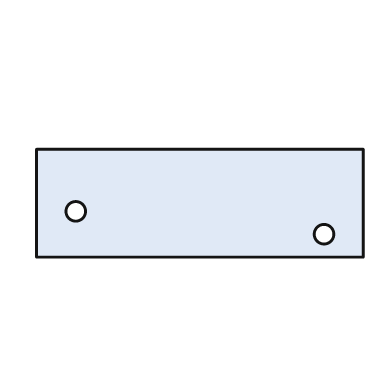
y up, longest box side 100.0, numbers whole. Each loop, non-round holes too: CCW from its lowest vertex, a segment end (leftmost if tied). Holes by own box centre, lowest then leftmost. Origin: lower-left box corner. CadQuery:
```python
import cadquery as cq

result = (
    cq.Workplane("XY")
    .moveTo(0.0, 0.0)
    .lineTo(100.0, 0.0)
    .lineTo(100.0, 33.0)
    .lineTo(0.0, 33.0)
    .close()
    .moveTo(88.0, 7.0)
    .circle(3.0)
    .moveTo(12.0, 14.0)
    .circle(3.0)
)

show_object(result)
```